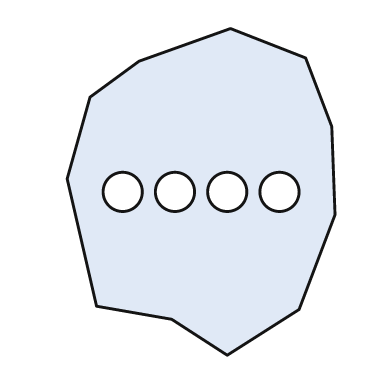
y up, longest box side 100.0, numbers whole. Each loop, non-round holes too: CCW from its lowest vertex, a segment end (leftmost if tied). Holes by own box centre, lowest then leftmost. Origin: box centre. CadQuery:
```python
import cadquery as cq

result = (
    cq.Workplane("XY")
    .moveTo(8.0, -50.0)
    .lineTo(30.0, -36.0)
    .lineTo(41.0, -7.0)
    .lineTo(40.0, 20.0)
    .lineTo(32.0, 41.0)
    .lineTo(9.0, 50.0)
    .lineTo(-19.0, 40.0)
    .lineTo(-34.0, 29.0)
    .lineTo(-41.0, 4.0)
    .lineTo(-32.0, -35.0)
    .lineTo(-9.0, -39.0)
    .close()
    .moveTo(-24.0, 0.0)
    .circle(6.0)
    .moveTo(-8.0, 0.0)
    .circle(6.0)
    .moveTo(8.0, 0.0)
    .circle(6.0)
    .moveTo(24.0, 0.0)
    .circle(6.0)
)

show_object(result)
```